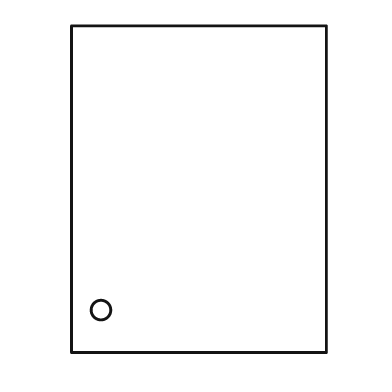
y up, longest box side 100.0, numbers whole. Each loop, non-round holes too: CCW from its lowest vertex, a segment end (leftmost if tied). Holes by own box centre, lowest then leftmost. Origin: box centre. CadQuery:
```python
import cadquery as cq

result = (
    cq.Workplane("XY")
    .moveTo(-39.0, -50.0)
    .lineTo(39.0, -50.0)
    .lineTo(39.0, 50.0)
    .lineTo(-39.0, 50.0)
    .close()
    .moveTo(-30.0, -37.0)
    .circle(3.0)
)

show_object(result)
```